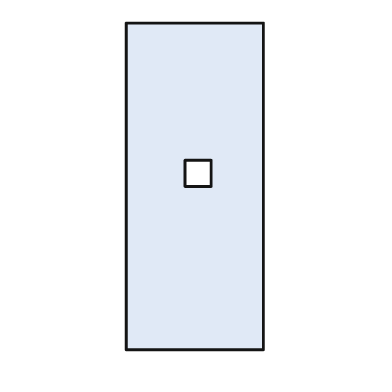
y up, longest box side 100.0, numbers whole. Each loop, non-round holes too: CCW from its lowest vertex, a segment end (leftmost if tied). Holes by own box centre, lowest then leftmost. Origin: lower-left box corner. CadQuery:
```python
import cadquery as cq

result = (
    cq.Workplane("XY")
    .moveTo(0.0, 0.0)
    .lineTo(42.0, 0.0)
    .lineTo(42.0, 100.0)
    .lineTo(0.0, 100.0)
    .close()
    .moveTo(18.0, 50.0)
    .lineTo(26.0, 50.0)
    .lineTo(26.0, 58.0)
    .lineTo(18.0, 58.0)
    .close()
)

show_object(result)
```